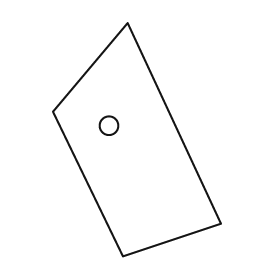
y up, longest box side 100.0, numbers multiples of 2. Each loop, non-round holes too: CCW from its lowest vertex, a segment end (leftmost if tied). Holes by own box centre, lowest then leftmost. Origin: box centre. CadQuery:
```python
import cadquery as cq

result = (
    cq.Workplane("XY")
    .moveTo(-6.0, -50.0)
    .lineTo(36.0, -36.0)
    .lineTo(-4.0, 50.0)
    .lineTo(-36.0, 12.0)
    .close()
    .moveTo(-12.0, 6.0)
    .circle(4.0)
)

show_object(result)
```